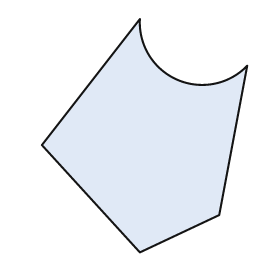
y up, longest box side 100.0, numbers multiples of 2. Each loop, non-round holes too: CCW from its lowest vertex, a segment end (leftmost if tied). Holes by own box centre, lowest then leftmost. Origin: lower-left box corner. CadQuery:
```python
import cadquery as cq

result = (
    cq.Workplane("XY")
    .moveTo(42.0, 0.0)
    .lineTo(76.0, 16.0)
    .lineTo(88.0, 80.0)
    .threePointArc((58.0, 74.0), (42.0, 100.0))
    .lineTo(0.0, 46.0)
    .close()
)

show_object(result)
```